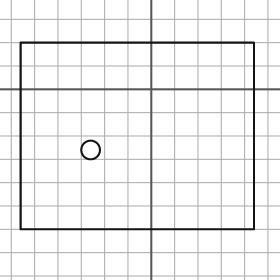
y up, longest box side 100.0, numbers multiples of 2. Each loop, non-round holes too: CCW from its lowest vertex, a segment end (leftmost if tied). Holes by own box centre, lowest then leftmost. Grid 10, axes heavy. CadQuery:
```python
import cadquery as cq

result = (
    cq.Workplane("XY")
    .moveTo(-56.0, -60.0)
    .lineTo(44.0, -60.0)
    .lineTo(44.0, 20.0)
    .lineTo(-56.0, 20.0)
    .close()
    .moveTo(-26.0, -26.0)
    .circle(4.0)
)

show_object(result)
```